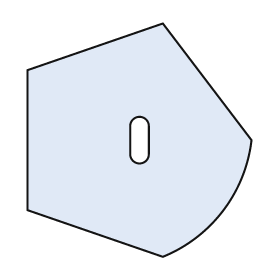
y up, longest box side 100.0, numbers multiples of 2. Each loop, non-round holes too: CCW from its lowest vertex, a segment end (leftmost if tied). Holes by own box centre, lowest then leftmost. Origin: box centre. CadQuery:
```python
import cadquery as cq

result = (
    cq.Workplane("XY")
    .moveTo(10.0, -50.0)
    .threePointArc((36.0, -30.0), (48.0, 0.0))
    .lineTo(10.0, 50.0)
    .lineTo(-48.0, 30.0)
    .lineTo(-48.0, -30.0)
    .close()
    .moveTo(-4.0, -6.0)
    .threePointArc((0.0, -10.0), (4.0, -6.0))
    .lineTo(4.0, 6.0)
    .threePointArc((0.0, 10.0), (-4.0, 6.0))
    .close()
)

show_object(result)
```